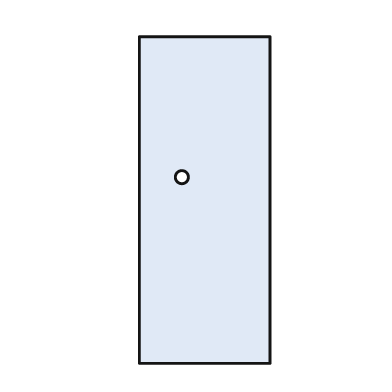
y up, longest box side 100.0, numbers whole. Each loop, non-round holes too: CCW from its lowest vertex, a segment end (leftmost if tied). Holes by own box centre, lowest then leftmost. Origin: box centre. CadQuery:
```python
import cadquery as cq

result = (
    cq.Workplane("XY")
    .moveTo(-20.0, -50.0)
    .lineTo(20.0, -50.0)
    .lineTo(20.0, 50.0)
    .lineTo(-20.0, 50.0)
    .close()
    .moveTo(-7.0, 7.0)
    .circle(2.0)
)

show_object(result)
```